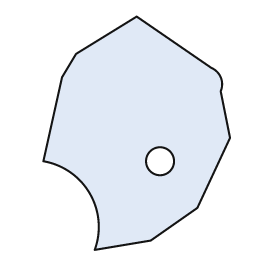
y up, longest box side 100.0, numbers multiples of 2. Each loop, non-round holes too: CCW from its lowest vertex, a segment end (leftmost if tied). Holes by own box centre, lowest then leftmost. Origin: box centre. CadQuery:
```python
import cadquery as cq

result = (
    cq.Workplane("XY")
    .moveTo(-18.0, -50.0)
    .lineTo(6.0, -46.0)
    .lineTo(26.0, -32.0)
    .lineTo(40.0, -2.0)
    .lineTo(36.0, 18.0)
    .threePointArc((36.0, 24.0), (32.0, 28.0))
    .lineTo(0.0, 50.0)
    .lineTo(-26.0, 34.0)
    .lineTo(-32.0, 24.0)
    .lineTo(-40.0, -12.0)
    .threePointArc((-20.0, -26.0), (-18.0, -50.0))
    .close()
    .moveTo(10.0, -12.0)
    .circle(6.0)
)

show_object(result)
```